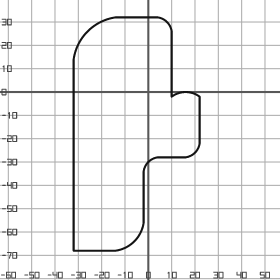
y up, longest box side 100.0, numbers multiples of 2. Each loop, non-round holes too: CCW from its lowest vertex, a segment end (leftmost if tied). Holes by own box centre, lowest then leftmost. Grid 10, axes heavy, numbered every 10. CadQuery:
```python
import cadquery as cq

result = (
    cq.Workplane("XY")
    .moveTo(-32.0, -68.0)
    .lineTo(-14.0, -68.0)
    .threePointArc((-6.0, -64.0), (-2.0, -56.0))
    .lineTo(-2.0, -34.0)
    .threePointArc((0.0, -30.0), (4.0, -28.0))
    .lineTo(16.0, -28.0)
    .threePointArc((20.0, -26.0), (22.0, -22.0))
    .lineTo(22.0, -2.0)
    .threePointArc((16.0, 0.0), (10.0, -2.0))
    .lineTo(10.0, 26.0)
    .threePointArc((8.0, 30.0), (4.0, 32.0))
    .lineTo(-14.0, 32.0)
    .threePointArc((-26.0, 26.0), (-32.0, 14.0))
    .close()
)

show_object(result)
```